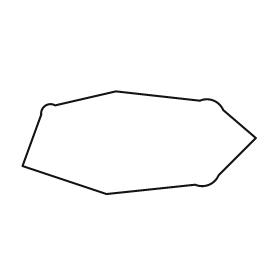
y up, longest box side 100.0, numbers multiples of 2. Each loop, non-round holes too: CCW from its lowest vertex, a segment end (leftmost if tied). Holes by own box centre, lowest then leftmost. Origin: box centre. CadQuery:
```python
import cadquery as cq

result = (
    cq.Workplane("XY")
    .moveTo(-14.0, -22.0)
    .lineTo(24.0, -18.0)
    .threePointArc((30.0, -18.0), (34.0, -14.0))
    .lineTo(50.0, 2.0)
    .lineTo(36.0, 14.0)
    .threePointArc((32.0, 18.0), (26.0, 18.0))
    .lineTo(-10.0, 22.0)
    .lineTo(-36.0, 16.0)
    .threePointArc((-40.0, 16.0), (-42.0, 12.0))
    .lineTo(-50.0, -10.0)
    .close()
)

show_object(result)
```